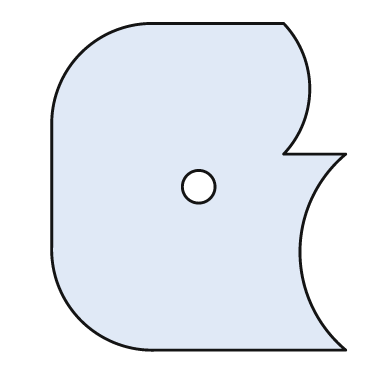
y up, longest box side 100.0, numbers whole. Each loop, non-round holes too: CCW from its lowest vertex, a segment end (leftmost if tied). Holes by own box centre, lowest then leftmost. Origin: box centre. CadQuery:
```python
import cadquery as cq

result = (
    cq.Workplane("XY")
    .moveTo(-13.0, -50.0)
    .lineTo(45.0, -50.0)
    .threePointArc((31.0, -20.0), (45.0, 10.0))
    .lineTo(26.0, 10.0)
    .threePointArc((34.0, 30.0), (26.0, 50.0))
    .lineTo(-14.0, 50.0)
    .threePointArc((-36.0, 41.0), (-45.0, 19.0))
    .lineTo(-45.0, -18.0)
    .threePointArc((-36.0, -41.0), (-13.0, -50.0))
    .close()
    .moveTo(0.0, 0.0)
    .circle(5.0)
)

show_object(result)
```